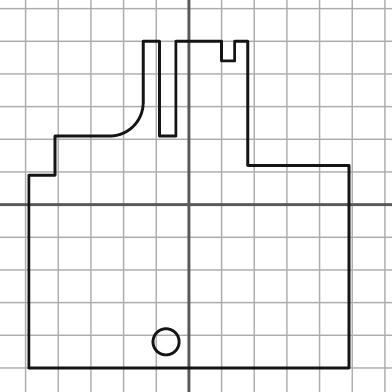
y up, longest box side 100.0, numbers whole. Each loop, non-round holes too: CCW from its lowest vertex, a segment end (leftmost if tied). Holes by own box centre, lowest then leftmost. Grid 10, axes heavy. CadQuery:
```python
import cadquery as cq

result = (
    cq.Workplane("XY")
    .moveTo(-49.0, -50.0)
    .lineTo(49.0, -50.0)
    .lineTo(49.0, 12.0)
    .lineTo(18.0, 12.0)
    .lineTo(18.0, 50.0)
    .lineTo(14.0, 50.0)
    .lineTo(14.0, 44.0)
    .lineTo(10.0, 44.0)
    .lineTo(10.0, 50.0)
    .lineTo(-4.0, 50.0)
    .lineTo(-4.0, 21.0)
    .lineTo(-9.0, 21.0)
    .lineTo(-9.0, 50.0)
    .lineTo(-14.0, 50.0)
    .lineTo(-14.0, 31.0)
    .threePointArc((-17.0, 24.0), (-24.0, 21.0))
    .lineTo(-41.0, 21.0)
    .lineTo(-41.0, 9.0)
    .lineTo(-49.0, 9.0)
    .close()
    .moveTo(-7.0, -42.0)
    .circle(4.0)
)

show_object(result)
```